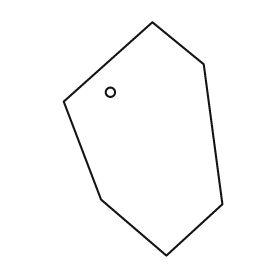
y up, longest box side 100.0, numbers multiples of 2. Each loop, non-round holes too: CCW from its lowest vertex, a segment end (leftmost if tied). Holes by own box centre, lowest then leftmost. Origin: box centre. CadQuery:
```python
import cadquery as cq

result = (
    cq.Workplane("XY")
    .moveTo(10.0, -50.0)
    .lineTo(34.0, -28.0)
    .lineTo(26.0, 32.0)
    .lineTo(4.0, 50.0)
    .lineTo(-34.0, 16.0)
    .lineTo(-18.0, -26.0)
    .close()
    .moveTo(-14.0, 20.0)
    .circle(2.0)
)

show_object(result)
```